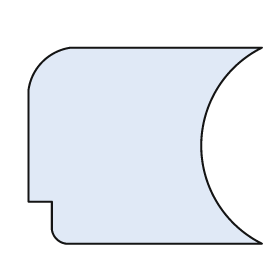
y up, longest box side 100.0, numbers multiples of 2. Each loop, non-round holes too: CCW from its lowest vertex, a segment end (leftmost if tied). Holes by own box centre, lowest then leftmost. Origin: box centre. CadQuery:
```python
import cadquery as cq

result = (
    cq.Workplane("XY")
    .moveTo(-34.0, -42.0)
    .lineTo(50.0, -42.0)
    .threePointArc((24.0, 0.0), (50.0, 42.0))
    .lineTo(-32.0, 42.0)
    .threePointArc((-44.0, 36.0), (-50.0, 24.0))
    .lineTo(-50.0, -24.0)
    .lineTo(-40.0, -24.0)
    .lineTo(-40.0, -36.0)
    .threePointArc((-38.0, -40.0), (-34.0, -42.0))
    .close()
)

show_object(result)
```